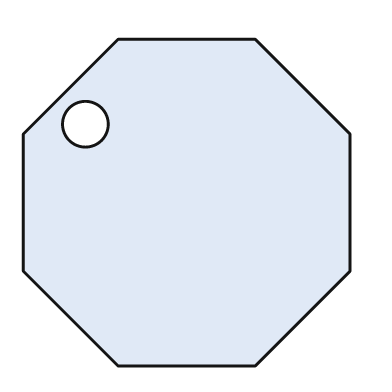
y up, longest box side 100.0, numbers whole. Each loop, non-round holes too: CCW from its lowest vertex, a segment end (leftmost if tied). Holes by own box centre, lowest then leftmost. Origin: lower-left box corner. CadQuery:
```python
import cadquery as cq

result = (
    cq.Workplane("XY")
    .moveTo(29.0, 0.0)
    .lineTo(71.0, 0.0)
    .lineTo(100.0, 29.0)
    .lineTo(100.0, 71.0)
    .lineTo(71.0, 100.0)
    .lineTo(29.0, 100.0)
    .lineTo(0.0, 71.0)
    .lineTo(0.0, 29.0)
    .close()
    .moveTo(19.0, 74.0)
    .circle(7.0)
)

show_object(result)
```